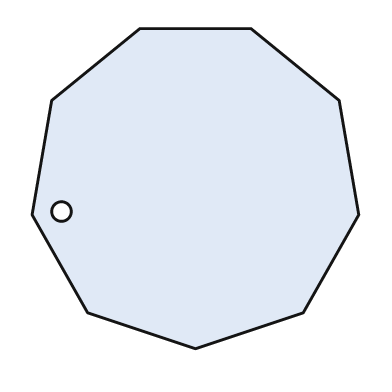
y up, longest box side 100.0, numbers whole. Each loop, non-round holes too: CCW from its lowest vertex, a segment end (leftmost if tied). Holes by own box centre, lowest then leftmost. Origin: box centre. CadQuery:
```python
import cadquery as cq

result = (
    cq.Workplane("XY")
    .moveTo(0.0, -49.0)
    .lineTo(33.0, -38.0)
    .lineTo(50.0, -8.0)
    .lineTo(44.0, 27.0)
    .lineTo(17.0, 49.0)
    .lineTo(-17.0, 49.0)
    .lineTo(-44.0, 27.0)
    .lineTo(-50.0, -8.0)
    .lineTo(-33.0, -38.0)
    .close()
    .moveTo(-41.0, -7.0)
    .circle(3.0)
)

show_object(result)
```